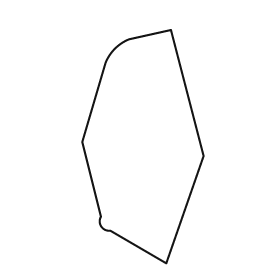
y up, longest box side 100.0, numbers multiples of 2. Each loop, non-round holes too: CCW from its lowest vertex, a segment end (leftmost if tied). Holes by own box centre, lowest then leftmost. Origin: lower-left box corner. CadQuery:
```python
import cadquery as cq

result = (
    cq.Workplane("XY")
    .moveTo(36.0, 0.0)
    .lineTo(52.0, 46.0)
    .lineTo(38.0, 100.0)
    .lineTo(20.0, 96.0)
    .threePointArc((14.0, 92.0), (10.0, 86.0))
    .lineTo(0.0, 52.0)
    .lineTo(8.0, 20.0)
    .threePointArc((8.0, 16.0), (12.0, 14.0))
    .close()
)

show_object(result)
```